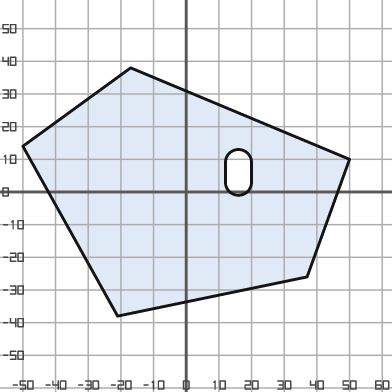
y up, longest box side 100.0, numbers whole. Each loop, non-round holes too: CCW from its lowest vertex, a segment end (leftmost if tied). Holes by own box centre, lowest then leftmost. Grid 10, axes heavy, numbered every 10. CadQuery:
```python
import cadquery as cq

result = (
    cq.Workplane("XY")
    .moveTo(-21.0, -38.0)
    .lineTo(37.0, -26.0)
    .lineTo(50.0, 10.0)
    .lineTo(-17.0, 38.0)
    .lineTo(-50.0, 14.0)
    .close()
    .moveTo(12.0, 3.0)
    .threePointArc((16.0, -1.0), (20.0, 3.0))
    .lineTo(20.0, 9.0)
    .threePointArc((16.0, 13.0), (12.0, 9.0))
    .close()
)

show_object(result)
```